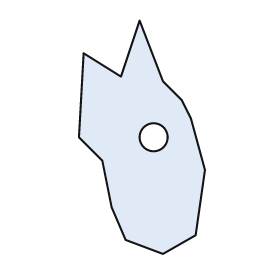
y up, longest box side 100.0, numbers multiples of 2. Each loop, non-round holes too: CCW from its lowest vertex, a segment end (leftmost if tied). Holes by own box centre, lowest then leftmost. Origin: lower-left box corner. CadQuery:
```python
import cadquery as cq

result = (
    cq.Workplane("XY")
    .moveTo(36.0, 0.0)
    .lineTo(50.0, 8.0)
    .lineTo(54.0, 36.0)
    .lineTo(48.0, 58.0)
    .lineTo(44.0, 66.0)
    .lineTo(36.0, 74.0)
    .lineTo(26.0, 100.0)
    .lineTo(18.0, 76.0)
    .lineTo(2.0, 86.0)
    .lineTo(0.0, 50.0)
    .lineTo(10.0, 40.0)
    .lineTo(14.0, 20.0)
    .lineTo(20.0, 6.0)
    .close()
    .moveTo(32.0, 50.0)
    .circle(6.0)
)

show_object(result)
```